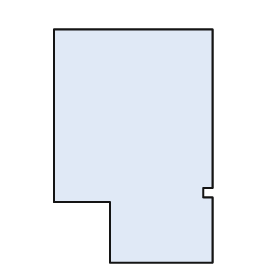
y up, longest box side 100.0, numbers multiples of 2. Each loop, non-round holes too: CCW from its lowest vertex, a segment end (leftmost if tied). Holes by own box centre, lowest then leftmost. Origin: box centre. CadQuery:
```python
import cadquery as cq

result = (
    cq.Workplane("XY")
    .moveTo(-10.0, -50.0)
    .lineTo(34.0, -50.0)
    .lineTo(34.0, -22.0)
    .lineTo(30.0, -22.0)
    .lineTo(30.0, -18.0)
    .lineTo(34.0, -18.0)
    .lineTo(34.0, 50.0)
    .lineTo(-34.0, 50.0)
    .lineTo(-34.0, -24.0)
    .lineTo(-10.0, -24.0)
    .close()
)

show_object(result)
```